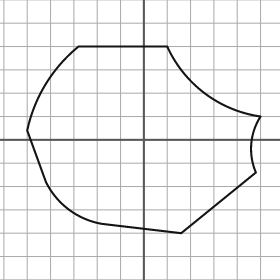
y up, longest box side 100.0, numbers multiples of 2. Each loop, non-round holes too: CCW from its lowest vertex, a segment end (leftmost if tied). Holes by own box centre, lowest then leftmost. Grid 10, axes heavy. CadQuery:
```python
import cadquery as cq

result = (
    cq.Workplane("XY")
    .moveTo(16.0, -40.0)
    .lineTo(48.0, -14.0)
    .threePointArc((46.0, -2.0), (50.0, 10.0))
    .threePointArc((26.0, 20.0), (10.0, 40.0))
    .lineTo(-28.0, 40.0)
    .threePointArc((-42.0, 24.0), (-50.0, 4.0))
    .lineTo(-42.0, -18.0)
    .threePointArc((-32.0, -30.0), (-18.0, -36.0))
    .close()
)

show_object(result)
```